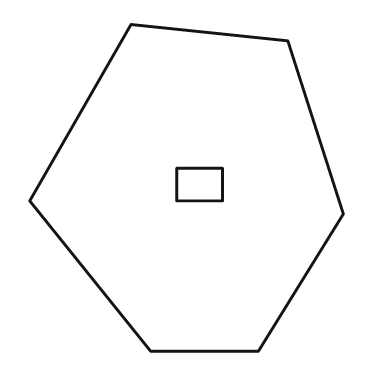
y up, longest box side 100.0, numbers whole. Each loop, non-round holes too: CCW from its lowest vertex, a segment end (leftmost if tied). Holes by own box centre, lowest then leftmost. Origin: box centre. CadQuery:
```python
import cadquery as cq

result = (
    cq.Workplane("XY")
    .moveTo(-11.0, -50.0)
    .lineTo(22.0, -50.0)
    .lineTo(48.0, -8.0)
    .lineTo(31.0, 45.0)
    .lineTo(-17.0, 50.0)
    .lineTo(-48.0, -4.0)
    .close()
    .moveTo(-3.0, -4.0)
    .lineTo(11.0, -4.0)
    .lineTo(11.0, 6.0)
    .lineTo(-3.0, 6.0)
    .close()
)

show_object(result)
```